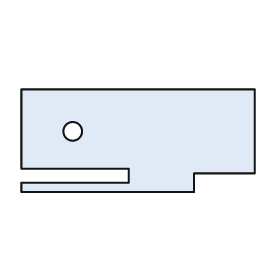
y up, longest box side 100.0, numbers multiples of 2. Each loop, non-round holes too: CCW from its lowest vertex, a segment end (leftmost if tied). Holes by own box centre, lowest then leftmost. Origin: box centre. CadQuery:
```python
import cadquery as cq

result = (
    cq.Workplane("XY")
    .moveTo(-50.0, -22.0)
    .lineTo(24.0, -22.0)
    .lineTo(24.0, -14.0)
    .lineTo(50.0, -14.0)
    .lineTo(50.0, 22.0)
    .lineTo(-50.0, 22.0)
    .lineTo(-50.0, -12.0)
    .lineTo(-4.0, -12.0)
    .lineTo(-4.0, -18.0)
    .lineTo(-50.0, -18.0)
    .close()
    .moveTo(-28.0, 4.0)
    .circle(4.0)
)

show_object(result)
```